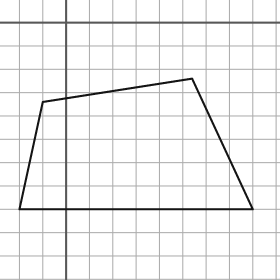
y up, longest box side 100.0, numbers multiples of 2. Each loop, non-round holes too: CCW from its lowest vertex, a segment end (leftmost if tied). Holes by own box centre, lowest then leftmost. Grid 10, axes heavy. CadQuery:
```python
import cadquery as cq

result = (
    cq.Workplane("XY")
    .moveTo(-20.0, -80.0)
    .lineTo(80.0, -80.0)
    .lineTo(54.0, -24.0)
    .lineTo(-10.0, -34.0)
    .close()
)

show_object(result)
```